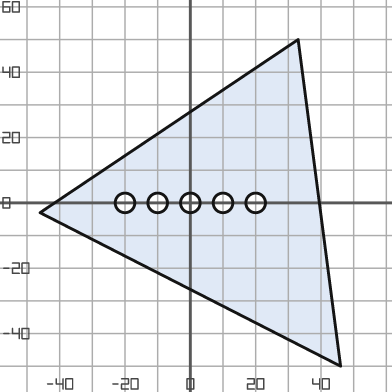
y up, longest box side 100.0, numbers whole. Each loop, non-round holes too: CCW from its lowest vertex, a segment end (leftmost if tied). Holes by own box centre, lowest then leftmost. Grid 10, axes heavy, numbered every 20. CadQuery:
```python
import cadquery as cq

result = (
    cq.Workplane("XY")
    .moveTo(46.0, -50.0)
    .lineTo(33.0, 50.0)
    .lineTo(-46.0, -3.0)
    .close()
    .moveTo(-20.0, 0.0)
    .circle(3.0)
    .moveTo(-10.0, 0.0)
    .circle(3.0)
    .moveTo(0.0, 0.0)
    .circle(3.0)
    .moveTo(10.0, 0.0)
    .circle(3.0)
    .moveTo(20.0, 0.0)
    .circle(3.0)
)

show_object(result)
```